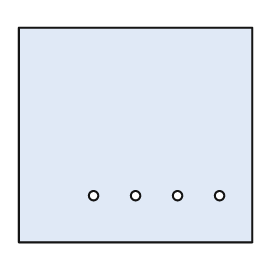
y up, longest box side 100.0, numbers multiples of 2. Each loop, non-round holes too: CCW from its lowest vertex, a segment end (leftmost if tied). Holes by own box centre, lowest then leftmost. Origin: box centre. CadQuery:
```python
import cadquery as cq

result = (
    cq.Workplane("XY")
    .moveTo(-50.0, -46.0)
    .lineTo(50.0, -46.0)
    .lineTo(50.0, 46.0)
    .lineTo(-50.0, 46.0)
    .close()
    .moveTo(-18.0, -26.0)
    .circle(2.0)
    .moveTo(0.0, -26.0)
    .circle(2.0)
    .moveTo(18.0, -26.0)
    .circle(2.0)
    .moveTo(36.0, -26.0)
    .circle(2.0)
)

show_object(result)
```